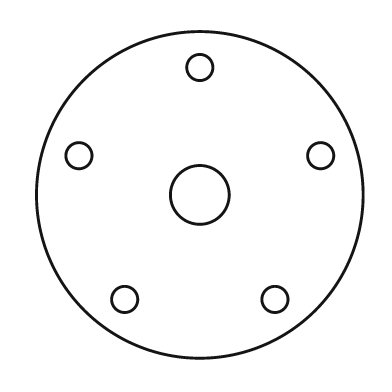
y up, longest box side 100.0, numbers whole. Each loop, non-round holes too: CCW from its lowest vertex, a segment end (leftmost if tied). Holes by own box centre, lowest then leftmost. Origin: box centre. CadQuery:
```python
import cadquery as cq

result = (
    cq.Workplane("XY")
    .moveTo(0.0, 0.0)
    .circle(50.0)
    .moveTo(-23.0, -32.0)
    .circle(4.0)
    .moveTo(23.0, -32.0)
    .circle(4.0)
    .moveTo(0.0, 0.0)
    .circle(9.0)
    .moveTo(-37.0, 12.0)
    .circle(4.0)
    .moveTo(37.0, 12.0)
    .circle(4.0)
    .moveTo(0.0, 39.0)
    .circle(4.0)
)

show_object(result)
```